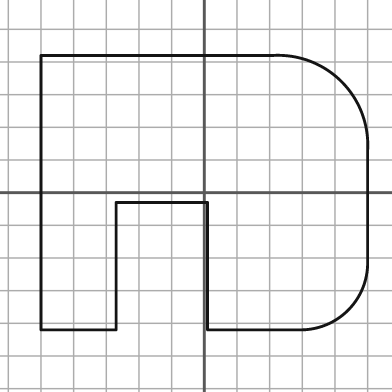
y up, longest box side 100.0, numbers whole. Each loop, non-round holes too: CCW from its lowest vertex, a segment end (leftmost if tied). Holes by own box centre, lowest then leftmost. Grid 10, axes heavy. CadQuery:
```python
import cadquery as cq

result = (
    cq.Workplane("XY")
    .moveTo(-50.0, -42.0)
    .lineTo(-27.0, -42.0)
    .lineTo(-27.0, -3.0)
    .lineTo(1.0, -3.0)
    .lineTo(1.0, -42.0)
    .lineTo(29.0, -42.0)
    .threePointArc((44.0, -36.0), (50.0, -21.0))
    .lineTo(50.0, 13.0)
    .threePointArc((42.0, 34.0), (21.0, 42.0))
    .lineTo(-50.0, 42.0)
    .close()
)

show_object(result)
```